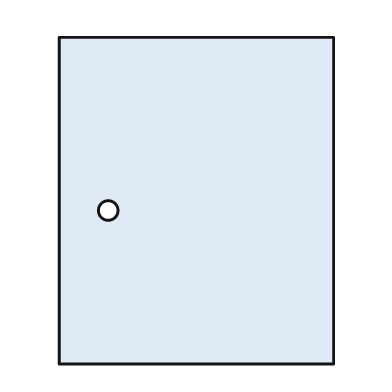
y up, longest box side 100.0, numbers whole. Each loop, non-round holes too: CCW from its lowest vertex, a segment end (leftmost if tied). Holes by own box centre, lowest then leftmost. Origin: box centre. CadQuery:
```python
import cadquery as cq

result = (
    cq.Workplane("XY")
    .moveTo(-42.0, -50.0)
    .lineTo(42.0, -50.0)
    .lineTo(42.0, 50.0)
    .lineTo(-42.0, 50.0)
    .close()
    .moveTo(-27.0, -3.0)
    .circle(3.0)
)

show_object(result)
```